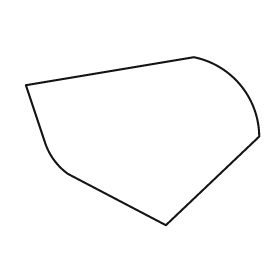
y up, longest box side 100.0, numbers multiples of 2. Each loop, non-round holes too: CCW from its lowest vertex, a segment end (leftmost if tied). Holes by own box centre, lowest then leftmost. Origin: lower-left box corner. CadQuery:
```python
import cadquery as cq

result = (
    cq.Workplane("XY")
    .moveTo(60.0, 0.0)
    .lineTo(100.0, 38.0)
    .threePointArc((92.0, 60.0), (72.0, 72.0))
    .lineTo(0.0, 60.0)
    .lineTo(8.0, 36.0)
    .threePointArc((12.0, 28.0), (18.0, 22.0))
    .close()
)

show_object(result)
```